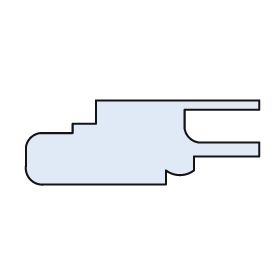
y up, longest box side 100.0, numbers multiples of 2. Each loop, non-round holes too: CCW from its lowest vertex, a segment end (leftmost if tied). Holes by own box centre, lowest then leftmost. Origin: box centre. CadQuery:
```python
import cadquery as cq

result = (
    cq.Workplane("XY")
    .moveTo(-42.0, -18.0)
    .lineTo(10.0, -18.0)
    .lineTo(10.0, -12.0)
    .threePointArc((16.0, -14.0), (22.0, -12.0))
    .lineTo(22.0, -6.0)
    .lineTo(50.0, -6.0)
    .lineTo(50.0, 0.0)
    .lineTo(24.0, 0.0)
    .threePointArc((20.0, 2.0), (18.0, 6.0))
    .lineTo(18.0, 14.0)
    .lineTo(50.0, 14.0)
    .lineTo(50.0, 18.0)
    .lineTo(-20.0, 18.0)
    .lineTo(-20.0, 8.0)
    .lineTo(-30.0, 8.0)
    .lineTo(-30.0, 4.0)
    .lineTo(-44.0, 4.0)
    .threePointArc((-48.0, 2.0), (-50.0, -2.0))
    .lineTo(-50.0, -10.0)
    .threePointArc((-48.0, -16.0), (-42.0, -18.0))
    .close()
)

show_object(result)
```